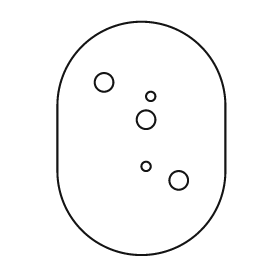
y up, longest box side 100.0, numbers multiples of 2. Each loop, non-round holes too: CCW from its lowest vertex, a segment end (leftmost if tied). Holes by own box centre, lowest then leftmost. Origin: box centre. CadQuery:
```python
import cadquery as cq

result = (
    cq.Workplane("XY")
    .moveTo(-36.0, -14.0)
    .threePointArc((0.0, -50.0), (36.0, -14.0))
    .lineTo(36.0, 14.0)
    .threePointArc((0.0, 50.0), (-36.0, 14.0))
    .close()
    .moveTo(16.0, -18.0)
    .circle(4.0)
    .moveTo(2.0, -12.0)
    .circle(2.0)
    .moveTo(2.0, 8.0)
    .circle(4.0)
    .moveTo(4.0, 18.0)
    .circle(2.0)
    .moveTo(-16.0, 24.0)
    .circle(4.0)
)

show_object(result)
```